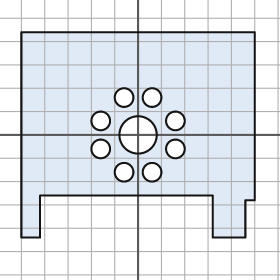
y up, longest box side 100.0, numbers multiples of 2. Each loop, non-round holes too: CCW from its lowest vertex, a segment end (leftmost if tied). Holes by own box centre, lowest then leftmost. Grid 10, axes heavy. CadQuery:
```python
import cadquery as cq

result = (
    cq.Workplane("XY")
    .moveTo(-50.0, -44.0)
    .lineTo(-42.0, -44.0)
    .lineTo(-42.0, -26.0)
    .lineTo(32.0, -26.0)
    .lineTo(32.0, -44.0)
    .lineTo(46.0, -44.0)
    .lineTo(46.0, -28.0)
    .lineTo(50.0, -28.0)
    .lineTo(50.0, 44.0)
    .lineTo(-50.0, 44.0)
    .close()
    .moveTo(-6.0, -16.0)
    .circle(4.0)
    .moveTo(6.0, -16.0)
    .circle(4.0)
    .moveTo(-16.0, -6.0)
    .circle(4.0)
    .moveTo(16.0, -6.0)
    .circle(4.0)
    .moveTo(0.0, 0.0)
    .circle(8.0)
    .moveTo(-16.0, 6.0)
    .circle(4.0)
    .moveTo(16.0, 6.0)
    .circle(4.0)
    .moveTo(-6.0, 16.0)
    .circle(4.0)
    .moveTo(6.0, 16.0)
    .circle(4.0)
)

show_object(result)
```